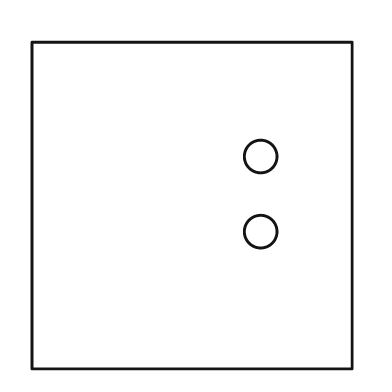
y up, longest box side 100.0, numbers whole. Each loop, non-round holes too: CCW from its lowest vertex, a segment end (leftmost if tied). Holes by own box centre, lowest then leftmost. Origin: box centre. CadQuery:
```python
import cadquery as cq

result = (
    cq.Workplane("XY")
    .moveTo(-49.0, -50.0)
    .lineTo(49.0, -50.0)
    .lineTo(49.0, 50.0)
    .lineTo(-49.0, 50.0)
    .close()
    .moveTo(21.0, -8.0)
    .circle(5.0)
    .moveTo(21.0, 15.0)
    .circle(5.0)
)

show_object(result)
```